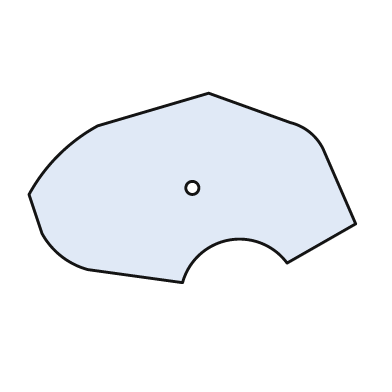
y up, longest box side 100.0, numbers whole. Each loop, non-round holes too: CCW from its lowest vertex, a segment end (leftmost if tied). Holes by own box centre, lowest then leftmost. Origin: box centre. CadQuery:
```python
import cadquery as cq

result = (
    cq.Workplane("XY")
    .moveTo(-3.0, -29.0)
    .threePointArc((11.0, -16.0), (29.0, -23.0))
    .lineTo(50.0, -11.0)
    .lineTo(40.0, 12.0)
    .threePointArc((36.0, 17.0), (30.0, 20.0))
    .lineTo(5.0, 29.0)
    .lineTo(-29.0, 19.0)
    .threePointArc((-41.0, 10.0), (-50.0, -2.0))
    .lineTo(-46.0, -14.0)
    .threePointArc((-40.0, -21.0), (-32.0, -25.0))
    .close()
    .moveTo(0.0, 0.0)
    .circle(2.0)
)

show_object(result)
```